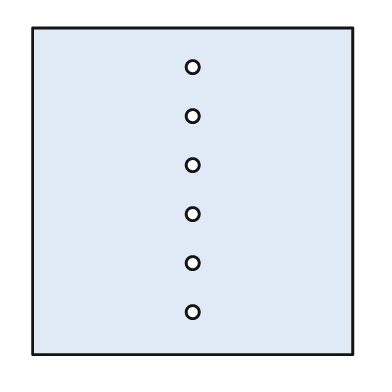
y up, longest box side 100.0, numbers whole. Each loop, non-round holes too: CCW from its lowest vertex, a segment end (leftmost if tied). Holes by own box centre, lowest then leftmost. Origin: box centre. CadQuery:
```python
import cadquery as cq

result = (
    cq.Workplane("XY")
    .moveTo(-49.0, -50.0)
    .lineTo(49.0, -50.0)
    .lineTo(49.0, 50.0)
    .lineTo(-49.0, 50.0)
    .close()
    .moveTo(0.0, -37.0)
    .circle(2.0)
    .moveTo(0.0, -22.0)
    .circle(2.0)
    .moveTo(0.0, -7.0)
    .circle(2.0)
    .moveTo(0.0, 8.0)
    .circle(2.0)
    .moveTo(0.0, 23.0)
    .circle(2.0)
    .moveTo(0.0, 38.0)
    .circle(2.0)
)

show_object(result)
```